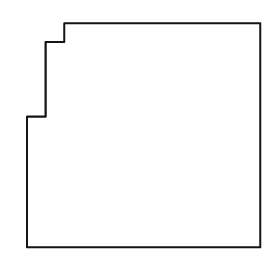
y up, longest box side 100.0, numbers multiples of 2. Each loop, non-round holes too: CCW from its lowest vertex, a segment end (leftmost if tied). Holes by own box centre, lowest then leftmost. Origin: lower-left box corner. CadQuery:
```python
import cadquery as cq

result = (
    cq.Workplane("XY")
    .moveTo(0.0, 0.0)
    .lineTo(100.0, 0.0)
    .lineTo(100.0, 96.0)
    .lineTo(16.0, 96.0)
    .lineTo(16.0, 88.0)
    .lineTo(8.0, 88.0)
    .lineTo(8.0, 56.0)
    .lineTo(0.0, 56.0)
    .close()
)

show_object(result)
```